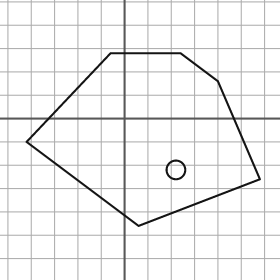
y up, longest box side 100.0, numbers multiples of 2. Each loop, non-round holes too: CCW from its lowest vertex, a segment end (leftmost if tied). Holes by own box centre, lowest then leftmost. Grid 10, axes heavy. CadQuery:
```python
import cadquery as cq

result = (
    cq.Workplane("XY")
    .moveTo(6.0, -46.0)
    .lineTo(58.0, -26.0)
    .lineTo(40.0, 16.0)
    .lineTo(24.0, 28.0)
    .lineTo(-6.0, 28.0)
    .lineTo(-42.0, -10.0)
    .close()
    .moveTo(22.0, -22.0)
    .circle(4.0)
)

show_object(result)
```